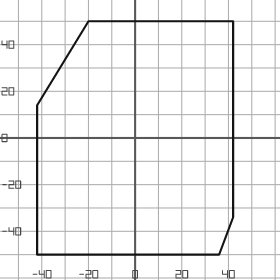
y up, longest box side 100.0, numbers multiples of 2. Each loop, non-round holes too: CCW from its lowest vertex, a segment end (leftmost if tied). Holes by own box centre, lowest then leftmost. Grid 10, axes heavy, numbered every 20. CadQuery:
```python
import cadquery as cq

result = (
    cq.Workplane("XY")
    .moveTo(-42.0, -50.0)
    .lineTo(36.0, -50.0)
    .lineTo(42.0, -34.0)
    .lineTo(42.0, 50.0)
    .lineTo(-20.0, 50.0)
    .lineTo(-42.0, 14.0)
    .close()
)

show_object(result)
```